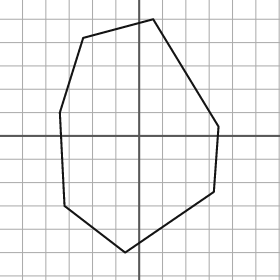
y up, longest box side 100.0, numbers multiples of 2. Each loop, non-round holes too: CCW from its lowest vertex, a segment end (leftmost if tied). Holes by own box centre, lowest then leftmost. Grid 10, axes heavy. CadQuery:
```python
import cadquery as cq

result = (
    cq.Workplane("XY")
    .moveTo(-6.0, -50.0)
    .lineTo(32.0, -24.0)
    .lineTo(34.0, 4.0)
    .lineTo(6.0, 50.0)
    .lineTo(-24.0, 42.0)
    .lineTo(-34.0, 10.0)
    .lineTo(-32.0, -30.0)
    .close()
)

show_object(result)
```